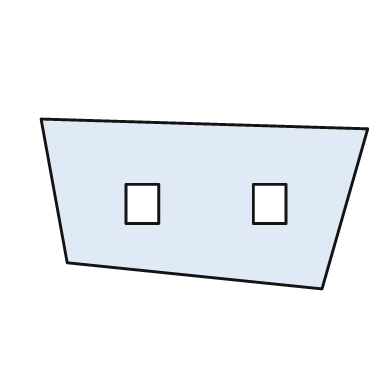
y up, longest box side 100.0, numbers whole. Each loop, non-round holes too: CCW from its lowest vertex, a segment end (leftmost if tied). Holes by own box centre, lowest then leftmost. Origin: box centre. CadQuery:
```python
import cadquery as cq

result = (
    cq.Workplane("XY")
    .moveTo(36.0, -26.0)
    .lineTo(50.0, 23.0)
    .lineTo(-50.0, 26.0)
    .lineTo(-42.0, -18.0)
    .close()
    .moveTo(-24.0, -6.0)
    .lineTo(-14.0, -6.0)
    .lineTo(-14.0, 6.0)
    .lineTo(-24.0, 6.0)
    .close()
    .moveTo(15.0, -6.0)
    .lineTo(25.0, -6.0)
    .lineTo(25.0, 6.0)
    .lineTo(15.0, 6.0)
    .close()
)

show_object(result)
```